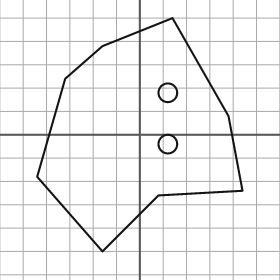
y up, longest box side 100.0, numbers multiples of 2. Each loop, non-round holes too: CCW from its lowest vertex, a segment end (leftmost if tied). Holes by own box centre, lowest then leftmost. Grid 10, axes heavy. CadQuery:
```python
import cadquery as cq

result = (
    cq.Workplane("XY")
    .moveTo(-16.0, -50.0)
    .lineTo(8.0, -26.0)
    .lineTo(44.0, -24.0)
    .lineTo(38.0, 8.0)
    .lineTo(14.0, 50.0)
    .lineTo(-16.0, 38.0)
    .lineTo(-32.0, 24.0)
    .lineTo(-44.0, -18.0)
    .close()
    .moveTo(12.0, -4.0)
    .circle(4.0)
    .moveTo(12.0, 18.0)
    .circle(4.0)
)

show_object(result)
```